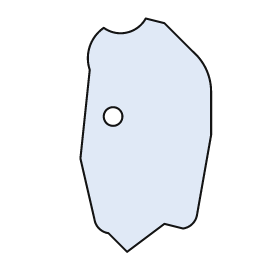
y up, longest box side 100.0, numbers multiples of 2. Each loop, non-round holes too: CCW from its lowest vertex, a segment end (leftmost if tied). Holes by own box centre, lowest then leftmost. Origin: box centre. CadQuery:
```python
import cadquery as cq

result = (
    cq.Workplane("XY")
    .moveTo(-8.0, -50.0)
    .lineTo(8.0, -38.0)
    .lineTo(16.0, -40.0)
    .threePointArc((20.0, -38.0), (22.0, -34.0))
    .lineTo(28.0, 0.0)
    .lineTo(28.0, 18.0)
    .threePointArc((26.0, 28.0), (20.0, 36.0))
    .lineTo(8.0, 48.0)
    .lineTo(0.0, 50.0)
    .threePointArc((-8.0, 44.0), (-18.0, 46.0))
    .threePointArc((-24.0, 38.0), (-24.0, 28.0))
    .lineTo(-28.0, -10.0)
    .lineTo(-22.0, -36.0)
    .threePointArc((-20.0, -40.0), (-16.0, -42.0))
    .close()
    .moveTo(-14.0, 8.0)
    .circle(4.0)
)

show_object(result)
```